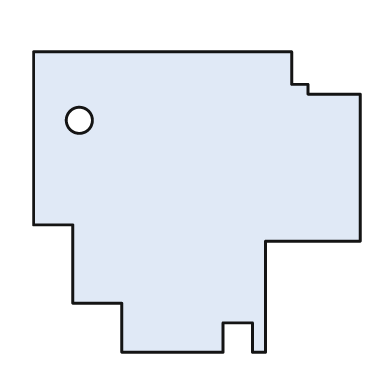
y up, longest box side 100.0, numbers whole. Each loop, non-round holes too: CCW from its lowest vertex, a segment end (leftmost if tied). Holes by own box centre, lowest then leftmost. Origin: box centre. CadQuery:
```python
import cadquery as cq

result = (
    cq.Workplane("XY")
    .moveTo(-23.0, -46.0)
    .lineTo(8.0, -46.0)
    .lineTo(8.0, -37.0)
    .lineTo(17.0, -37.0)
    .lineTo(17.0, -46.0)
    .lineTo(21.0, -46.0)
    .lineTo(21.0, -12.0)
    .lineTo(50.0, -12.0)
    .lineTo(50.0, 33.0)
    .lineTo(34.0, 33.0)
    .lineTo(34.0, 36.0)
    .lineTo(29.0, 36.0)
    .lineTo(29.0, 46.0)
    .lineTo(-50.0, 46.0)
    .lineTo(-50.0, -7.0)
    .lineTo(-38.0, -7.0)
    .lineTo(-38.0, -31.0)
    .lineTo(-23.0, -31.0)
    .close()
    .moveTo(-36.0, 25.0)
    .circle(4.0)
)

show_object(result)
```